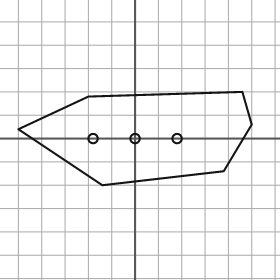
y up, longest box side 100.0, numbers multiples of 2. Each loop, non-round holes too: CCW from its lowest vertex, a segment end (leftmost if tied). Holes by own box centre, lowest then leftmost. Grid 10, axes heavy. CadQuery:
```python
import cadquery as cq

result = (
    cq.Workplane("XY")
    .moveTo(-14.0, -20.0)
    .lineTo(38.0, -14.0)
    .lineTo(50.0, 6.0)
    .lineTo(46.0, 20.0)
    .lineTo(-20.0, 18.0)
    .lineTo(-50.0, 4.0)
    .close()
    .moveTo(-18.0, 0.0)
    .circle(2.0)
    .moveTo(0.0, 0.0)
    .circle(2.0)
    .moveTo(18.0, 0.0)
    .circle(2.0)
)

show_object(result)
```